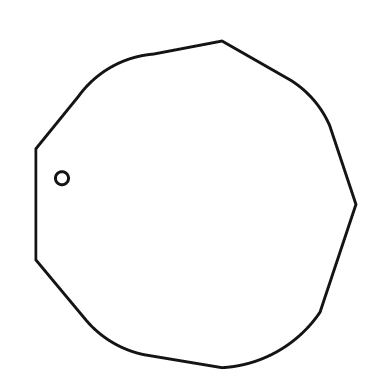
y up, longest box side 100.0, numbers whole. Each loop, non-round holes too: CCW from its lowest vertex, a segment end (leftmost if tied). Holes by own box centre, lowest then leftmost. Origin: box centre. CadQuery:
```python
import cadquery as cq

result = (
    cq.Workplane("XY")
    .moveTo(8.0, -50.0)
    .threePointArc((25.0, -45.0), (38.0, -33.0))
    .lineTo(49.0, 0.0)
    .lineTo(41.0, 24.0)
    .threePointArc((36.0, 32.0), (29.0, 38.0))
    .lineTo(8.0, 50.0)
    .lineTo(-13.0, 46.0)
    .threePointArc((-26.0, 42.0), (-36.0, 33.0))
    .lineTo(-49.0, 17.0)
    .lineTo(-49.0, -17.0)
    .lineTo(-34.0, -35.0)
    .threePointArc((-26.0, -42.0), (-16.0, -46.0))
    .close()
    .moveTo(-41.0, 8.0)
    .circle(2.0)
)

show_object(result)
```